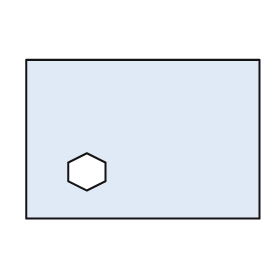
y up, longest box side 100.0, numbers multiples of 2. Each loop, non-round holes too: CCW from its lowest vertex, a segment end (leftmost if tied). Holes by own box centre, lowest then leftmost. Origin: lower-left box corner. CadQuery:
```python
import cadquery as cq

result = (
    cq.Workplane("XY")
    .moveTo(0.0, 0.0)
    .lineTo(100.0, 0.0)
    .lineTo(100.0, 68.0)
    .lineTo(0.0, 68.0)
    .close()
    .moveTo(26.0, 12.0)
    .lineTo(34.0, 16.0)
    .lineTo(34.0, 24.0)
    .lineTo(26.0, 28.0)
    .lineTo(18.0, 24.0)
    .lineTo(18.0, 16.0)
    .close()
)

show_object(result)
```